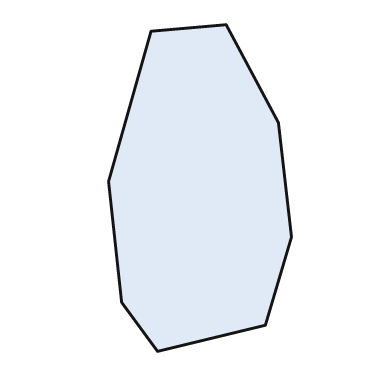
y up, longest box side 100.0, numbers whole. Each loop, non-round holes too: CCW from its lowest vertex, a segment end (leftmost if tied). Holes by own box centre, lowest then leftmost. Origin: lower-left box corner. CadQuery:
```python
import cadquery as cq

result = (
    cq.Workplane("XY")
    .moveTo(15.0, 0.0)
    .lineTo(48.0, 8.0)
    .lineTo(56.0, 35.0)
    .lineTo(52.0, 70.0)
    .lineTo(36.0, 100.0)
    .lineTo(13.0, 98.0)
    .lineTo(0.0, 52.0)
    .lineTo(4.0, 15.0)
    .close()
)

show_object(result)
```